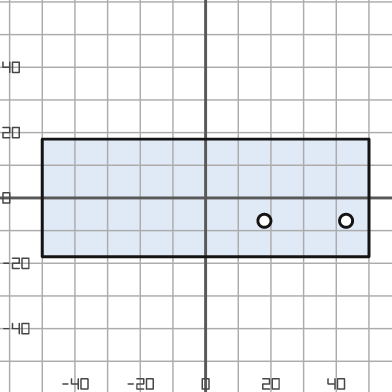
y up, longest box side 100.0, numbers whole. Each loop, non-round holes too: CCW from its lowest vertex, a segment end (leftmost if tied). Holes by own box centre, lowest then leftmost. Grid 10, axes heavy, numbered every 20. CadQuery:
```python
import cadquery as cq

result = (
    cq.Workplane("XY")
    .moveTo(-50.0, -18.0)
    .lineTo(50.0, -18.0)
    .lineTo(50.0, 18.0)
    .lineTo(-50.0, 18.0)
    .close()
    .moveTo(18.0, -7.0)
    .circle(2.0)
    .moveTo(43.0, -7.0)
    .circle(2.0)
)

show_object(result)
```